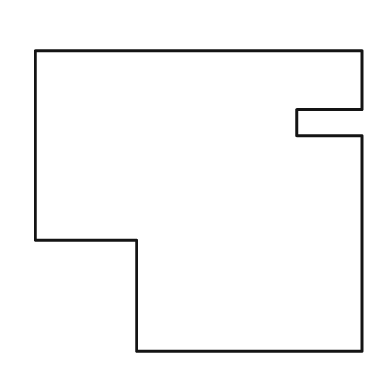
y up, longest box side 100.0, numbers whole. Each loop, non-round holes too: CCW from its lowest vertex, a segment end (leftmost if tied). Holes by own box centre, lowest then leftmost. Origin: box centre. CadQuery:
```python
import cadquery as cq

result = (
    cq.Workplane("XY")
    .moveTo(-19.0, -46.0)
    .lineTo(50.0, -46.0)
    .lineTo(50.0, 20.0)
    .lineTo(30.0, 20.0)
    .lineTo(30.0, 28.0)
    .lineTo(50.0, 28.0)
    .lineTo(50.0, 46.0)
    .lineTo(-50.0, 46.0)
    .lineTo(-50.0, -12.0)
    .lineTo(-19.0, -12.0)
    .close()
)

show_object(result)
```